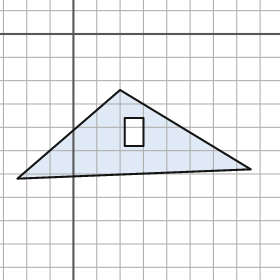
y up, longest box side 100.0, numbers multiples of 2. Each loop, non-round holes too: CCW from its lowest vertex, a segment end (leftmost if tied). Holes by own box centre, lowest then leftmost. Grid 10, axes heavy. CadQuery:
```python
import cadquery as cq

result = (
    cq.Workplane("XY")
    .moveTo(-24.0, -62.0)
    .lineTo(76.0, -58.0)
    .lineTo(20.0, -24.0)
    .close()
    .moveTo(22.0, -48.0)
    .lineTo(30.0, -48.0)
    .lineTo(30.0, -36.0)
    .lineTo(22.0, -36.0)
    .close()
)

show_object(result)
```